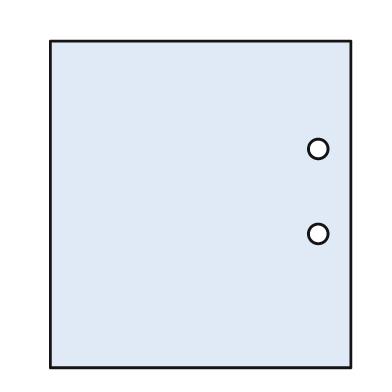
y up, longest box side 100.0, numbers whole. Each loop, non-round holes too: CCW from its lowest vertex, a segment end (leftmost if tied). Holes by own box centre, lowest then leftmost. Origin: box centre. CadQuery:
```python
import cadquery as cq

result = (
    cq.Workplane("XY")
    .moveTo(-46.0, -50.0)
    .lineTo(46.0, -50.0)
    .lineTo(46.0, 50.0)
    .lineTo(-46.0, 50.0)
    .close()
    .moveTo(36.0, -9.0)
    .circle(3.0)
    .moveTo(36.0, 17.0)
    .circle(3.0)
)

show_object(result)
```